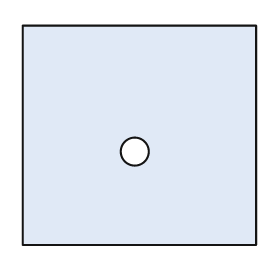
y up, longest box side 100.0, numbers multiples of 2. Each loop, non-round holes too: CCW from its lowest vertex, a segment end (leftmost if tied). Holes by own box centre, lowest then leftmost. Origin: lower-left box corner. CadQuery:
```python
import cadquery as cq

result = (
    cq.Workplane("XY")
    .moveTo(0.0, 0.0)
    .lineTo(100.0, 0.0)
    .lineTo(100.0, 94.0)
    .lineTo(0.0, 94.0)
    .close()
    .moveTo(48.0, 40.0)
    .circle(6.0)
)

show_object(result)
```